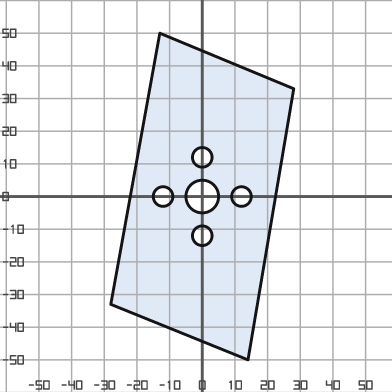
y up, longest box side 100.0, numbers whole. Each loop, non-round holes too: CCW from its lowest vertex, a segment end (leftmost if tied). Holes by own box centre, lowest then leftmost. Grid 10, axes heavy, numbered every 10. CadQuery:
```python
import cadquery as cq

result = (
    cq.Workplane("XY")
    .moveTo(14.0, -50.0)
    .lineTo(28.0, 33.0)
    .lineTo(-13.0, 50.0)
    .lineTo(-28.0, -33.0)
    .close()
    .moveTo(0.0, -12.0)
    .circle(3.0)
    .moveTo(-12.0, 0.0)
    .circle(3.0)
    .moveTo(0.0, 0.0)
    .circle(5.0)
    .moveTo(12.0, 0.0)
    .circle(3.0)
    .moveTo(0.0, 12.0)
    .circle(3.0)
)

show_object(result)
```